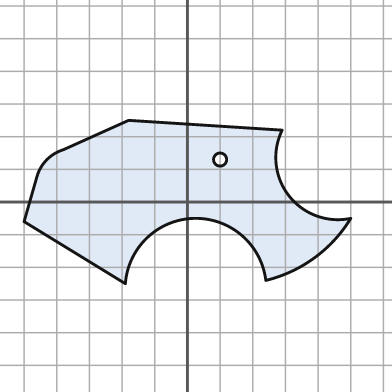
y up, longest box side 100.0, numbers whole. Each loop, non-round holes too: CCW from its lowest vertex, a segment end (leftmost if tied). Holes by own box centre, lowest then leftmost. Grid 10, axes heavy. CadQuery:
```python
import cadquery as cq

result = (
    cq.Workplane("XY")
    .moveTo(-19.0, -25.0)
    .threePointArc((2.0, -5.0), (24.0, -24.0))
    .threePointArc((39.0, -17.0), (50.0, -5.0))
    .threePointArc((31.0, 2.0), (29.0, 22.0))
    .lineTo(-18.0, 25.0)
    .lineTo(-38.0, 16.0)
    .threePointArc((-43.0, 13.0), (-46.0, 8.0))
    .lineTo(-50.0, -6.0)
    .close()
    .moveTo(10.0, 13.0)
    .circle(2.0)
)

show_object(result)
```